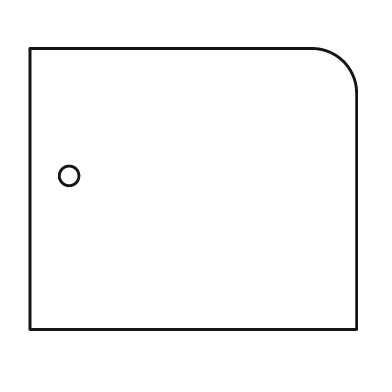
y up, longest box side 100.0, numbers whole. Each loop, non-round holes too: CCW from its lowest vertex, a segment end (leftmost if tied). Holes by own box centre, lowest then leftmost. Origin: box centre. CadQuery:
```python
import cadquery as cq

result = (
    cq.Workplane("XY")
    .moveTo(-50.0, -43.0)
    .lineTo(50.0, -43.0)
    .lineTo(50.0, 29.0)
    .threePointArc((46.0, 39.0), (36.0, 43.0))
    .lineTo(-50.0, 43.0)
    .close()
    .moveTo(-38.0, 4.0)
    .circle(3.0)
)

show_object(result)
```